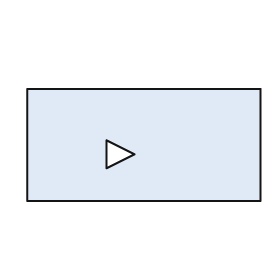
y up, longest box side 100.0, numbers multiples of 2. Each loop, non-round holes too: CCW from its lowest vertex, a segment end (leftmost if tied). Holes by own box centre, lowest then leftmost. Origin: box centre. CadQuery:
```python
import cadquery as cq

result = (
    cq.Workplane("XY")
    .moveTo(-50.0, -24.0)
    .lineTo(50.0, -24.0)
    .lineTo(50.0, 24.0)
    .lineTo(-50.0, 24.0)
    .close()
    .moveTo(-16.0, -10.0)
    .lineTo(-4.0, -4.0)
    .lineTo(-16.0, 2.0)
    .close()
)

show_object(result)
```